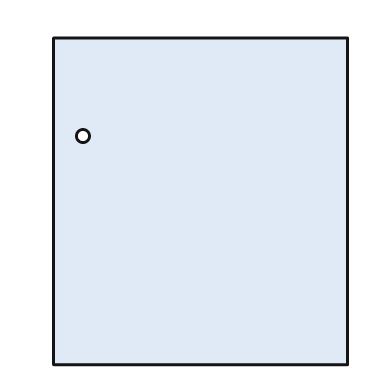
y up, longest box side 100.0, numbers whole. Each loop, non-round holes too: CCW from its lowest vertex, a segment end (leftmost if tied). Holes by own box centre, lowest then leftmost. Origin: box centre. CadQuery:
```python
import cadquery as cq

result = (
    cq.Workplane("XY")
    .moveTo(-45.0, -50.0)
    .lineTo(45.0, -50.0)
    .lineTo(45.0, 50.0)
    .lineTo(-45.0, 50.0)
    .close()
    .moveTo(-36.0, 20.0)
    .circle(2.0)
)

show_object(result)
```